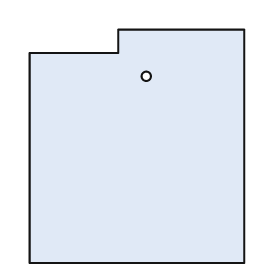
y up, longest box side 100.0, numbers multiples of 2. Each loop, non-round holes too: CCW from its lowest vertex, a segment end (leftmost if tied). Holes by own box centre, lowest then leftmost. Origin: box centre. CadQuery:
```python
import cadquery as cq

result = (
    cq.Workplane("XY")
    .moveTo(-46.0, -50.0)
    .lineTo(46.0, -50.0)
    .lineTo(46.0, 50.0)
    .lineTo(-8.0, 50.0)
    .lineTo(-8.0, 40.0)
    .lineTo(-46.0, 40.0)
    .close()
    .moveTo(4.0, 30.0)
    .circle(2.0)
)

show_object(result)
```